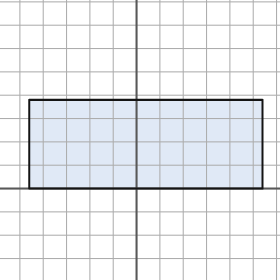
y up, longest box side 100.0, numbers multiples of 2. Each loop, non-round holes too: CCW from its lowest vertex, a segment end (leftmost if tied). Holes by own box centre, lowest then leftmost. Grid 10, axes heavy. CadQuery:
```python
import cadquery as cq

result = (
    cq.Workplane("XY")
    .moveTo(-46.0, 0.0)
    .lineTo(54.0, 0.0)
    .lineTo(54.0, 38.0)
    .lineTo(-46.0, 38.0)
    .close()
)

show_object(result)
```